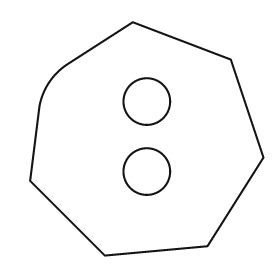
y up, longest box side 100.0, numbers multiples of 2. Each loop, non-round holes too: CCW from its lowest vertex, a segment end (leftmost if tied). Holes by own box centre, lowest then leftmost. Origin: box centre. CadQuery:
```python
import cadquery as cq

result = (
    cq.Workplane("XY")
    .moveTo(-18.0, -50.0)
    .lineTo(26.0, -46.0)
    .lineTo(50.0, -8.0)
    .lineTo(36.0, 34.0)
    .lineTo(-6.0, 50.0)
    .lineTo(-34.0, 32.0)
    .threePointArc((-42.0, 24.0), (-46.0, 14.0))
    .lineTo(-50.0, -18.0)
    .close()
    .moveTo(0.0, -14.0)
    .circle(10.0)
    .moveTo(0.0, 16.0)
    .circle(10.0)
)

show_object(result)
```